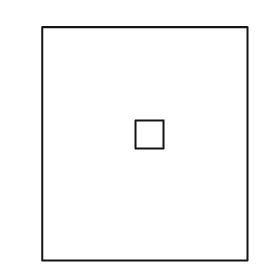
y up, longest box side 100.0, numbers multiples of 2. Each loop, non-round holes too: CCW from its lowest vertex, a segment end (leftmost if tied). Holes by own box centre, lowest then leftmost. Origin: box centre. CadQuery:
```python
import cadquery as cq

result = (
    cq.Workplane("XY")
    .moveTo(-44.0, -50.0)
    .lineTo(44.0, -50.0)
    .lineTo(44.0, 50.0)
    .lineTo(-44.0, 50.0)
    .close()
    .moveTo(-4.0, -2.0)
    .lineTo(8.0, -2.0)
    .lineTo(8.0, 10.0)
    .lineTo(-4.0, 10.0)
    .close()
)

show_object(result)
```